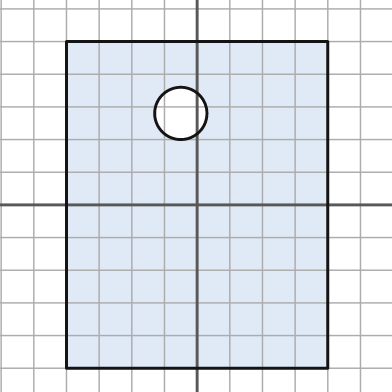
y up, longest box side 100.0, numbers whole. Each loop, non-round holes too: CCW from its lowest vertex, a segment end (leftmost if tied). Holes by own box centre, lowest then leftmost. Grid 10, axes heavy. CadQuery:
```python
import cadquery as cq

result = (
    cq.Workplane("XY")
    .moveTo(-40.0, -50.0)
    .lineTo(40.0, -50.0)
    .lineTo(40.0, 50.0)
    .lineTo(-40.0, 50.0)
    .close()
    .moveTo(-5.0, 28.0)
    .circle(8.0)
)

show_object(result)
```